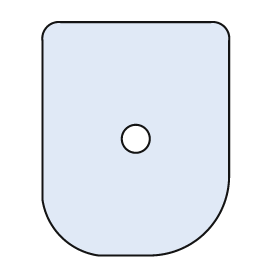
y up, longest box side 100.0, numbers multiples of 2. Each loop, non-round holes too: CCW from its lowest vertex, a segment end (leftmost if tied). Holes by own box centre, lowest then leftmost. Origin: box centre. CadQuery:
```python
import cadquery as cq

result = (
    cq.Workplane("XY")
    .moveTo(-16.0, -50.0)
    .lineTo(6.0, -50.0)
    .threePointArc((30.0, -40.0), (40.0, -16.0))
    .lineTo(40.0, 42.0)
    .threePointArc((38.0, 48.0), (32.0, 50.0))
    .lineTo(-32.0, 50.0)
    .threePointArc((-38.0, 48.0), (-40.0, 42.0))
    .lineTo(-40.0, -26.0)
    .threePointArc((-32.0, -42.0), (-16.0, -50.0))
    .close()
    .moveTo(0.0, 0.0)
    .circle(6.0)
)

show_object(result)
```